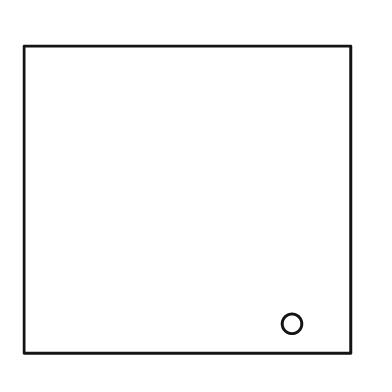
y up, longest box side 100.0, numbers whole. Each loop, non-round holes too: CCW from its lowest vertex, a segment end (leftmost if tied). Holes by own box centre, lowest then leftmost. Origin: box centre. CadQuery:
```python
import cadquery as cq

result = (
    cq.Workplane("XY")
    .moveTo(-50.0, -47.0)
    .lineTo(50.0, -47.0)
    .lineTo(50.0, 47.0)
    .lineTo(-50.0, 47.0)
    .close()
    .moveTo(32.0, -38.0)
    .circle(3.0)
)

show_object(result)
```